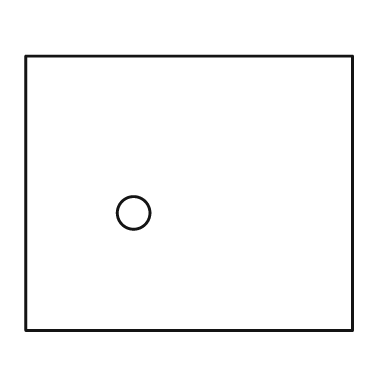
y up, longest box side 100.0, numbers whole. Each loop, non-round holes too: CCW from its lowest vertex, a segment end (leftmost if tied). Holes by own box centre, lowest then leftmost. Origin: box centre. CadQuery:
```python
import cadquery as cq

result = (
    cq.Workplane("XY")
    .moveTo(-50.0, -42.0)
    .lineTo(50.0, -42.0)
    .lineTo(50.0, 42.0)
    .lineTo(-50.0, 42.0)
    .close()
    .moveTo(-17.0, -6.0)
    .circle(5.0)
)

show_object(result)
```